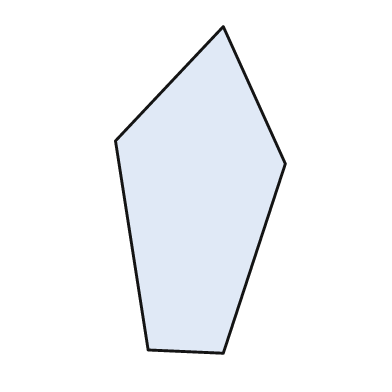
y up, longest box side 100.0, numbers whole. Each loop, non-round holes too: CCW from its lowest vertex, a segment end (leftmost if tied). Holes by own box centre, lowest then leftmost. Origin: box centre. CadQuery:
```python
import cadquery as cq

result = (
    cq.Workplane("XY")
    .moveTo(7.0, -50.0)
    .lineTo(26.0, 8.0)
    .lineTo(7.0, 50.0)
    .lineTo(-26.0, 15.0)
    .lineTo(-16.0, -49.0)
    .close()
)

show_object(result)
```